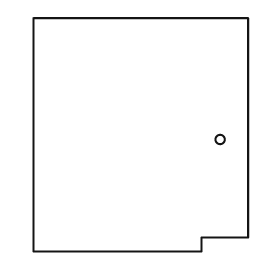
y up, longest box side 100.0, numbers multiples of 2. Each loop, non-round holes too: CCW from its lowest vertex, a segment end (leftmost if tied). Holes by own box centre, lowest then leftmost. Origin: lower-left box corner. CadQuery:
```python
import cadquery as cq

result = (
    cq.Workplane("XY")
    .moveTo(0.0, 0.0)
    .lineTo(72.0, 0.0)
    .lineTo(72.0, 6.0)
    .lineTo(92.0, 6.0)
    .lineTo(92.0, 100.0)
    .lineTo(0.0, 100.0)
    .close()
    .moveTo(80.0, 48.0)
    .circle(2.0)
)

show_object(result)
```